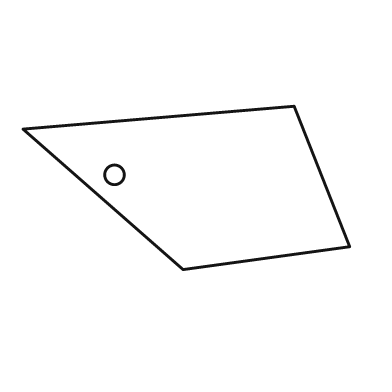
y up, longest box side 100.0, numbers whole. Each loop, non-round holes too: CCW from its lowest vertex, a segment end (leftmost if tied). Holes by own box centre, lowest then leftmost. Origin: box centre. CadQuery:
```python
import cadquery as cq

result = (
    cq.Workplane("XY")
    .moveTo(-1.0, -25.0)
    .lineTo(50.0, -18.0)
    .lineTo(33.0, 25.0)
    .lineTo(-50.0, 18.0)
    .close()
    .moveTo(-22.0, 4.0)
    .circle(3.0)
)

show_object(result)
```